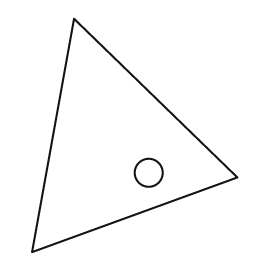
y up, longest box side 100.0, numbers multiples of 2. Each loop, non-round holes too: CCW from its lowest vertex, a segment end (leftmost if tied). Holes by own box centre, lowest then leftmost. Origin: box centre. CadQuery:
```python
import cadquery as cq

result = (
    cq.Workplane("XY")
    .moveTo(-44.0, -50.0)
    .lineTo(44.0, -18.0)
    .lineTo(-26.0, 50.0)
    .close()
    .moveTo(6.0, -16.0)
    .circle(6.0)
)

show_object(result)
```